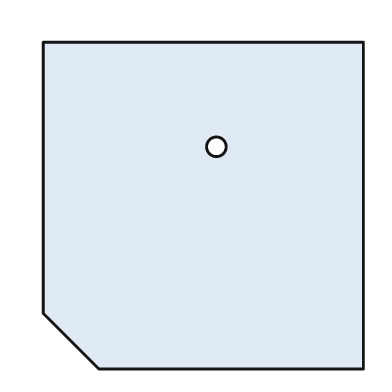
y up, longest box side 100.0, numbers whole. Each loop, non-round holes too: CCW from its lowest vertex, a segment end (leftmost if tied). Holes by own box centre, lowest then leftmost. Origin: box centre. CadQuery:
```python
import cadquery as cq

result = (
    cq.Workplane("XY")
    .moveTo(-32.0, -50.0)
    .lineTo(49.0, -50.0)
    .lineTo(49.0, 50.0)
    .lineTo(-49.0, 50.0)
    .lineTo(-49.0, -33.0)
    .close()
    .moveTo(4.0, 18.0)
    .circle(3.0)
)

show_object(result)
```